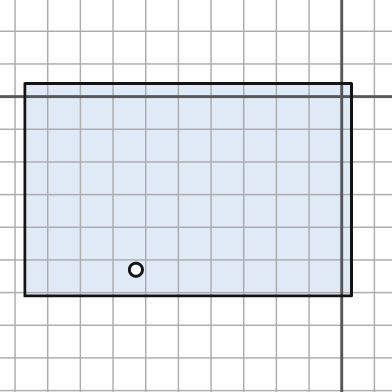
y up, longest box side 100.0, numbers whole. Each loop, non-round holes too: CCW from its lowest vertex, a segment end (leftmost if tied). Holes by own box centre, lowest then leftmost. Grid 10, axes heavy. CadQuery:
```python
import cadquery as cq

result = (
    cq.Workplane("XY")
    .moveTo(-97.0, -61.0)
    .lineTo(3.0, -61.0)
    .lineTo(3.0, 4.0)
    .lineTo(-97.0, 4.0)
    .close()
    .moveTo(-63.0, -53.0)
    .circle(2.0)
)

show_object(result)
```